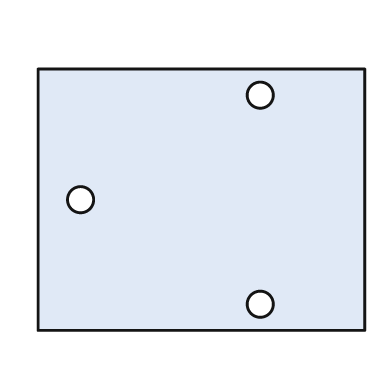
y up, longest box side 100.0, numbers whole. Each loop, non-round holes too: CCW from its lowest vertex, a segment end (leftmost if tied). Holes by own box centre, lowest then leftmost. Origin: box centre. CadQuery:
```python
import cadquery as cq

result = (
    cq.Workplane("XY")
    .moveTo(-50.0, -40.0)
    .lineTo(50.0, -40.0)
    .lineTo(50.0, 40.0)
    .lineTo(-50.0, 40.0)
    .close()
    .moveTo(18.0, -32.0)
    .circle(4.0)
    .moveTo(-37.0, 0.0)
    .circle(4.0)
    .moveTo(18.0, 32.0)
    .circle(4.0)
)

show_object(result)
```